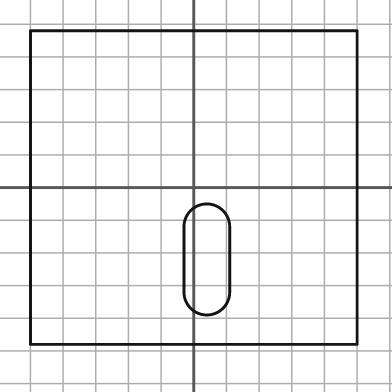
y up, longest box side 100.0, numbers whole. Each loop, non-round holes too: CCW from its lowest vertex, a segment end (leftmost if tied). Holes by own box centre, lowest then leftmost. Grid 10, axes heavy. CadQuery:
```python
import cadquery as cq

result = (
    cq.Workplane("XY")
    .moveTo(-50.0, -48.0)
    .lineTo(50.0, -48.0)
    .lineTo(50.0, 48.0)
    .lineTo(-50.0, 48.0)
    .close()
    .moveTo(-3.0, -32.0)
    .threePointArc((4.0, -39.0), (11.0, -32.0))
    .lineTo(11.0, -12.0)
    .threePointArc((4.0, -5.0), (-3.0, -12.0))
    .close()
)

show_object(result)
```